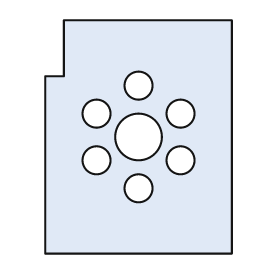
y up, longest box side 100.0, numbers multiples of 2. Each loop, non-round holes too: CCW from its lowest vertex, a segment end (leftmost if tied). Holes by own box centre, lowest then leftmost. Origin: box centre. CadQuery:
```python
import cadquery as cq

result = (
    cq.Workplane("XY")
    .moveTo(-40.0, -50.0)
    .lineTo(40.0, -50.0)
    .lineTo(40.0, 50.0)
    .lineTo(-32.0, 50.0)
    .lineTo(-32.0, 26.0)
    .lineTo(-40.0, 26.0)
    .close()
    .moveTo(0.0, -22.0)
    .circle(6.0)
    .moveTo(-18.0, -10.0)
    .circle(6.0)
    .moveTo(18.0, -10.0)
    .circle(6.0)
    .moveTo(0.0, 0.0)
    .circle(10.0)
    .moveTo(-18.0, 10.0)
    .circle(6.0)
    .moveTo(18.0, 10.0)
    .circle(6.0)
    .moveTo(0.0, 22.0)
    .circle(6.0)
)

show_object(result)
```